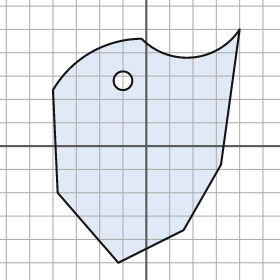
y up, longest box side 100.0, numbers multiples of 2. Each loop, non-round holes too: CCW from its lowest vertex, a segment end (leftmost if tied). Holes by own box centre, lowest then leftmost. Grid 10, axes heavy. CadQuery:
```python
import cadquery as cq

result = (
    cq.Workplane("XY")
    .moveTo(-12.0, -50.0)
    .lineTo(16.0, -36.0)
    .lineTo(32.0, -8.0)
    .lineTo(40.0, 50.0)
    .threePointArc((20.0, 38.0), (-2.0, 46.0))
    .threePointArc((-24.0, 40.0), (-40.0, 24.0))
    .lineTo(-38.0, -20.0)
    .close()
    .moveTo(-10.0, 28.0)
    .circle(4.0)
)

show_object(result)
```